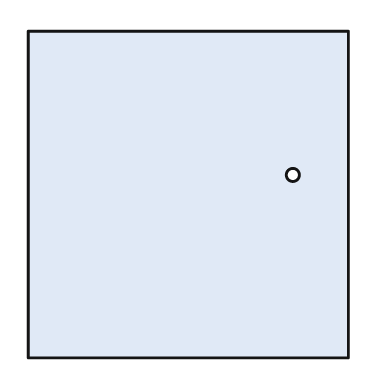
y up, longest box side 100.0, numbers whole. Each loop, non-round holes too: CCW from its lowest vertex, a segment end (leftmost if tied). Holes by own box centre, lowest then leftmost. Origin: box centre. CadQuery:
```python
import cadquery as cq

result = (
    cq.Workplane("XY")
    .moveTo(-49.0, -50.0)
    .lineTo(49.0, -50.0)
    .lineTo(49.0, 50.0)
    .lineTo(-49.0, 50.0)
    .close()
    .moveTo(32.0, 6.0)
    .circle(2.0)
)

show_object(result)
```